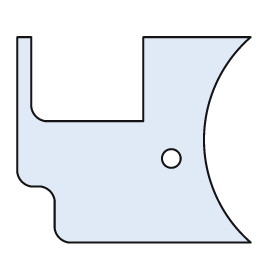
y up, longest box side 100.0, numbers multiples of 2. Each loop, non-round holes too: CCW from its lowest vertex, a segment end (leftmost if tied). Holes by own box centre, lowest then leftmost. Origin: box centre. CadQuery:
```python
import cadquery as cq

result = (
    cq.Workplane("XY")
    .moveTo(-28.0, -44.0)
    .lineTo(50.0, -44.0)
    .threePointArc((30.0, 0.0), (50.0, 44.0))
    .lineTo(4.0, 44.0)
    .lineTo(4.0, 8.0)
    .lineTo(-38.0, 8.0)
    .threePointArc((-42.0, 10.0), (-44.0, 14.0))
    .lineTo(-44.0, 44.0)
    .lineTo(-50.0, 44.0)
    .lineTo(-50.0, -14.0)
    .threePointArc((-48.0, -18.0), (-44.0, -20.0))
    .lineTo(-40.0, -20.0)
    .threePointArc((-36.0, -22.0), (-34.0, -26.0))
    .lineTo(-34.0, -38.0)
    .threePointArc((-32.0, -42.0), (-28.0, -44.0))
    .close()
    .moveTo(16.0, -8.0)
    .circle(4.0)
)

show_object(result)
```